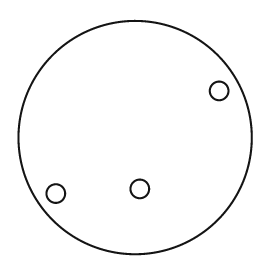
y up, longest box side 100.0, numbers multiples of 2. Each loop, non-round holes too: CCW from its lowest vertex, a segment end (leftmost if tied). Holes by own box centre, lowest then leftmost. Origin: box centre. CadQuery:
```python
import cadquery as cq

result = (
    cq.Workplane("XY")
    .moveTo(0.0, 0.0)
    .circle(50.0)
    .moveTo(-34.0, -24.0)
    .circle(4.0)
    .moveTo(2.0, -22.0)
    .circle(4.0)
    .moveTo(36.0, 20.0)
    .circle(4.0)
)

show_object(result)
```